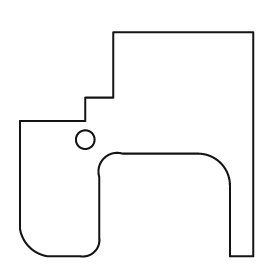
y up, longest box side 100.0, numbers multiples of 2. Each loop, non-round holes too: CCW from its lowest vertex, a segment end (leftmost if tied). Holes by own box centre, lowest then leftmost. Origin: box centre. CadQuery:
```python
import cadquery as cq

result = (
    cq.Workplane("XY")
    .moveTo(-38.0, -48.0)
    .lineTo(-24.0, -48.0)
    .threePointArc((-18.0, -46.0), (-16.0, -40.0))
    .lineTo(-16.0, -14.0)
    .threePointArc((-14.0, -6.0), (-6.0, -4.0))
    .lineTo(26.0, -4.0)
    .threePointArc((36.0, -8.0), (40.0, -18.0))
    .lineTo(40.0, -48.0)
    .lineTo(50.0, -48.0)
    .lineTo(50.0, 48.0)
    .lineTo(-10.0, 48.0)
    .lineTo(-10.0, 20.0)
    .lineTo(-22.0, 20.0)
    .lineTo(-22.0, 10.0)
    .lineTo(-50.0, 10.0)
    .lineTo(-50.0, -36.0)
    .threePointArc((-46.0, -44.0), (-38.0, -48.0))
    .close()
    .moveTo(-22.0, 2.0)
    .circle(4.0)
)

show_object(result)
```